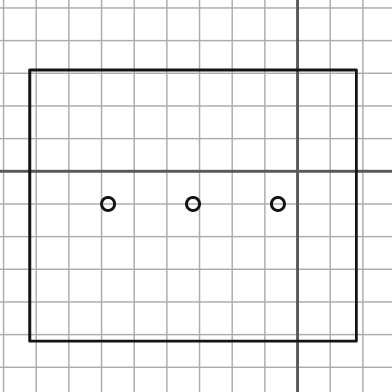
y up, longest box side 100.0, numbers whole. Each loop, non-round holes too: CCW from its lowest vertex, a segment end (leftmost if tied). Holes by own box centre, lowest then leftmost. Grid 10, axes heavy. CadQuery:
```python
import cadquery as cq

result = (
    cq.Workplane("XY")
    .moveTo(-82.0, -52.0)
    .lineTo(18.0, -52.0)
    .lineTo(18.0, 31.0)
    .lineTo(-82.0, 31.0)
    .close()
    .moveTo(-58.0, -10.0)
    .circle(2.0)
    .moveTo(-32.0, -10.0)
    .circle(2.0)
    .moveTo(-6.0, -10.0)
    .circle(2.0)
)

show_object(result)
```